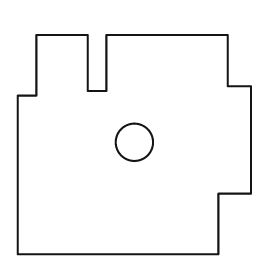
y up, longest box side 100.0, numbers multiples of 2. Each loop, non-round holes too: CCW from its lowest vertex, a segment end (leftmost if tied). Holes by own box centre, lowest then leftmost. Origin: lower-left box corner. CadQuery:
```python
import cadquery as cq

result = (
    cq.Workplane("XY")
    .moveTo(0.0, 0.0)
    .lineTo(86.0, 0.0)
    .lineTo(86.0, 26.0)
    .lineTo(100.0, 26.0)
    .lineTo(100.0, 72.0)
    .lineTo(90.0, 72.0)
    .lineTo(90.0, 94.0)
    .lineTo(38.0, 94.0)
    .lineTo(38.0, 70.0)
    .lineTo(30.0, 70.0)
    .lineTo(30.0, 94.0)
    .lineTo(8.0, 94.0)
    .lineTo(8.0, 68.0)
    .lineTo(0.0, 68.0)
    .close()
    .moveTo(50.0, 48.0)
    .circle(8.0)
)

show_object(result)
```